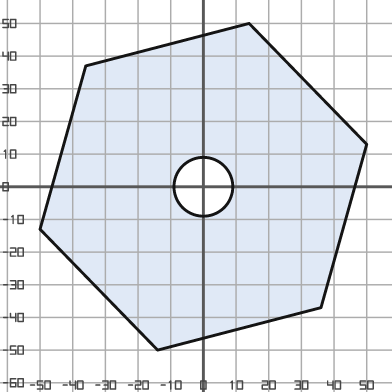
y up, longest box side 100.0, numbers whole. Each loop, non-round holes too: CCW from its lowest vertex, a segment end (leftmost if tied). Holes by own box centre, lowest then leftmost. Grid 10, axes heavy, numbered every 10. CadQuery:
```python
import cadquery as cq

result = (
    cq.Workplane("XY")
    .moveTo(-14.0, -50.0)
    .lineTo(36.0, -37.0)
    .lineTo(50.0, 13.0)
    .lineTo(14.0, 50.0)
    .lineTo(-36.0, 37.0)
    .lineTo(-50.0, -13.0)
    .close()
    .moveTo(0.0, 0.0)
    .circle(9.0)
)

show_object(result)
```